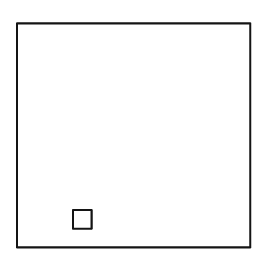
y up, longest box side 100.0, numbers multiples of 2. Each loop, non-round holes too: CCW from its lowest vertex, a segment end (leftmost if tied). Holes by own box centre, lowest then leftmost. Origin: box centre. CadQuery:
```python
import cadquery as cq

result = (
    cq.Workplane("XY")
    .moveTo(-50.0, -48.0)
    .lineTo(50.0, -48.0)
    .lineTo(50.0, 48.0)
    .lineTo(-50.0, 48.0)
    .close()
    .moveTo(-26.0, -40.0)
    .lineTo(-18.0, -40.0)
    .lineTo(-18.0, -32.0)
    .lineTo(-26.0, -32.0)
    .close()
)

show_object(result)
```